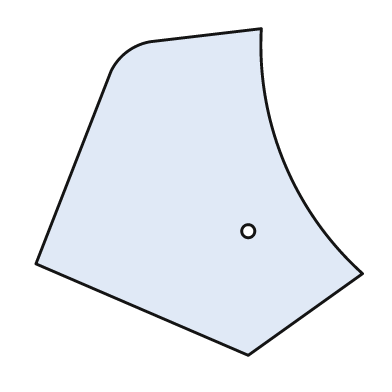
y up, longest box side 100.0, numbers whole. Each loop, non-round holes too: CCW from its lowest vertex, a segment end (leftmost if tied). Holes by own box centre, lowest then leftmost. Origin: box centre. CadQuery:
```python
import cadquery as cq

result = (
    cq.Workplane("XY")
    .moveTo(15.0, -50.0)
    .lineTo(50.0, -25.0)
    .threePointArc((26.0, 9.0), (19.0, 50.0))
    .lineTo(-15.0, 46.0)
    .threePointArc((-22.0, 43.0), (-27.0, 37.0))
    .lineTo(-50.0, -22.0)
    .close()
    .moveTo(15.0, -12.0)
    .circle(2.0)
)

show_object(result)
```